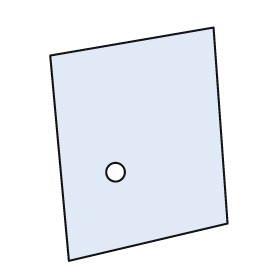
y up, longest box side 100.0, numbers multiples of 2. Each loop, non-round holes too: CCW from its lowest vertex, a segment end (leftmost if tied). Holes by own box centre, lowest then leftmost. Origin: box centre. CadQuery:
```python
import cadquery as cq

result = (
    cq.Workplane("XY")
    .moveTo(-30.0, -50.0)
    .lineTo(38.0, -34.0)
    .lineTo(32.0, 50.0)
    .lineTo(-38.0, 38.0)
    .close()
    .moveTo(-10.0, -12.0)
    .circle(4.0)
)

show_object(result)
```